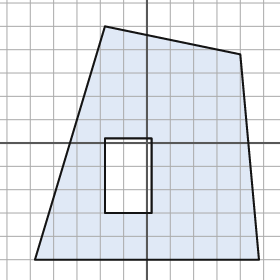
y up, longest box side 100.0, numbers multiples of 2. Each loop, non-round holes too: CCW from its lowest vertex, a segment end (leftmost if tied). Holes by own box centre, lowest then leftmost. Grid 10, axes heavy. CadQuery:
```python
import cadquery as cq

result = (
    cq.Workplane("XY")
    .moveTo(-48.0, -50.0)
    .lineTo(48.0, -50.0)
    .lineTo(40.0, 38.0)
    .lineTo(-18.0, 50.0)
    .close()
    .moveTo(-18.0, -30.0)
    .lineTo(2.0, -30.0)
    .lineTo(2.0, 2.0)
    .lineTo(-18.0, 2.0)
    .close()
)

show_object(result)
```